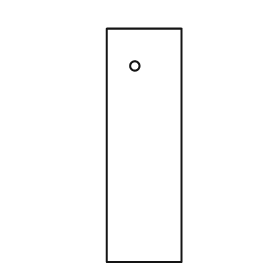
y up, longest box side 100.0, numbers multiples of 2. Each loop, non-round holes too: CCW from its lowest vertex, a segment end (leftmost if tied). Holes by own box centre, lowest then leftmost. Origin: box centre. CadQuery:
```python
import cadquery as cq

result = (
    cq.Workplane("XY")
    .moveTo(-16.0, -50.0)
    .lineTo(16.0, -50.0)
    .lineTo(16.0, 50.0)
    .lineTo(-16.0, 50.0)
    .close()
    .moveTo(-4.0, 34.0)
    .circle(2.0)
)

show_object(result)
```